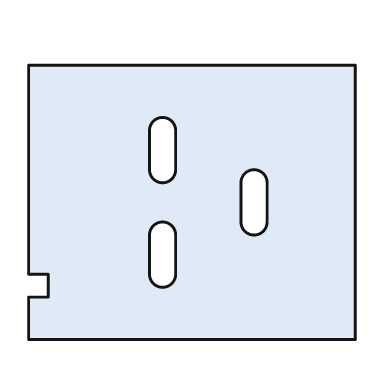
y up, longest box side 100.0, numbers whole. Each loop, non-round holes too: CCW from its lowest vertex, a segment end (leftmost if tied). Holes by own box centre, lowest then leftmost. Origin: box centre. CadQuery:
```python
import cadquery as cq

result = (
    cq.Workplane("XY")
    .moveTo(-50.0, -42.0)
    .lineTo(50.0, -42.0)
    .lineTo(50.0, 42.0)
    .lineTo(-50.0, 42.0)
    .lineTo(-50.0, -22.0)
    .lineTo(-44.0, -22.0)
    .lineTo(-44.0, -29.0)
    .lineTo(-50.0, -29.0)
    .close()
    .moveTo(-13.0, -22.0)
    .threePointArc((-9.0, -26.0), (-5.0, -22.0))
    .lineTo(-5.0, -10.0)
    .threePointArc((-9.0, -6.0), (-13.0, -10.0))
    .close()
    .moveTo(15.0, -6.0)
    .threePointArc((19.0, -10.0), (23.0, -6.0))
    .lineTo(23.0, 6.0)
    .threePointArc((19.0, 10.0), (15.0, 6.0))
    .close()
    .moveTo(-13.0, 10.0)
    .threePointArc((-9.0, 6.0), (-5.0, 10.0))
    .lineTo(-5.0, 22.0)
    .threePointArc((-9.0, 26.0), (-13.0, 22.0))
    .close()
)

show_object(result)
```